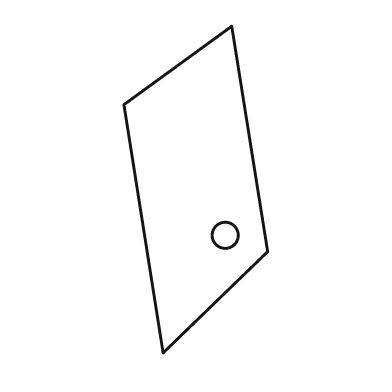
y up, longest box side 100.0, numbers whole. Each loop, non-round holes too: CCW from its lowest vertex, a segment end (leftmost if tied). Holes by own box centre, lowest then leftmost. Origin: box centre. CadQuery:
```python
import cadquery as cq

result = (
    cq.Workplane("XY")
    .moveTo(-10.0, -50.0)
    .lineTo(22.0, -19.0)
    .lineTo(11.0, 50.0)
    .lineTo(-22.0, 26.0)
    .close()
    .moveTo(9.0, -14.0)
    .circle(4.0)
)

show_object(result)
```